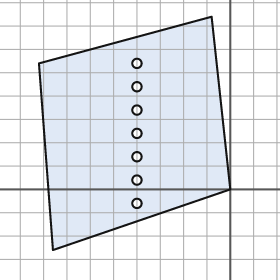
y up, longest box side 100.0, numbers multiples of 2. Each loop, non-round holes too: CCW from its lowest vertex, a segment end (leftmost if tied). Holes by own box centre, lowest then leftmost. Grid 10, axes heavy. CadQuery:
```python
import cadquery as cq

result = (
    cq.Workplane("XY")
    .moveTo(-76.0, -26.0)
    .lineTo(0.0, 0.0)
    .lineTo(-8.0, 74.0)
    .lineTo(-82.0, 54.0)
    .close()
    .moveTo(-40.0, -6.0)
    .circle(2.0)
    .moveTo(-40.0, 4.0)
    .circle(2.0)
    .moveTo(-40.0, 14.0)
    .circle(2.0)
    .moveTo(-40.0, 24.0)
    .circle(2.0)
    .moveTo(-40.0, 34.0)
    .circle(2.0)
    .moveTo(-40.0, 44.0)
    .circle(2.0)
    .moveTo(-40.0, 54.0)
    .circle(2.0)
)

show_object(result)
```